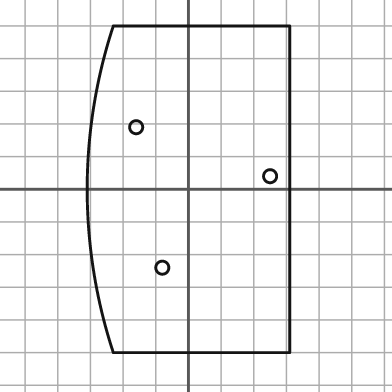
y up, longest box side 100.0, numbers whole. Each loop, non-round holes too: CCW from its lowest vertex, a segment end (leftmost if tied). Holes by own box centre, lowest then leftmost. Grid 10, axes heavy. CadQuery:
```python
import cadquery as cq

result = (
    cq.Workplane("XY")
    .moveTo(-23.0, -50.0)
    .lineTo(31.0, -50.0)
    .lineTo(31.0, 50.0)
    .lineTo(-23.0, 50.0)
    .threePointArc((-31.0, 0.0), (-23.0, -50.0))
    .close()
    .moveTo(-8.0, -24.0)
    .circle(2.0)
    .moveTo(25.0, 4.0)
    .circle(2.0)
    .moveTo(-16.0, 19.0)
    .circle(2.0)
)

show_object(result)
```